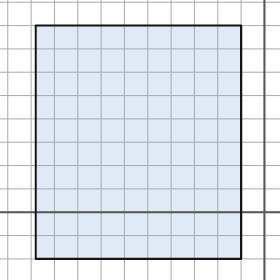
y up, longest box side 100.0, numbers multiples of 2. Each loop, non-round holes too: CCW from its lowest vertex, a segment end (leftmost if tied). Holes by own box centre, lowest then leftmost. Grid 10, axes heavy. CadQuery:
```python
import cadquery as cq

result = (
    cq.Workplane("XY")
    .moveTo(-98.0, -20.0)
    .lineTo(-10.0, -20.0)
    .lineTo(-10.0, 80.0)
    .lineTo(-98.0, 80.0)
    .close()
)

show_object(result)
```